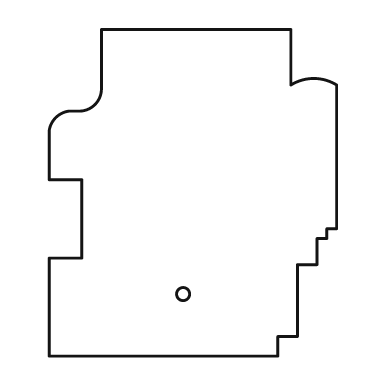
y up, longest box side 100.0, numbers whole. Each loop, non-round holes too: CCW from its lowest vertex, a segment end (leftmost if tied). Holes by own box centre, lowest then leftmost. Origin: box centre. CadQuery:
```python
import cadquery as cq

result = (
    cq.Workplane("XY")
    .moveTo(-44.0, -50.0)
    .lineTo(26.0, -50.0)
    .lineTo(26.0, -44.0)
    .lineTo(32.0, -44.0)
    .lineTo(32.0, -22.0)
    .lineTo(38.0, -22.0)
    .lineTo(38.0, -14.0)
    .lineTo(41.0, -14.0)
    .lineTo(41.0, -11.0)
    .lineTo(44.0, -11.0)
    .lineTo(44.0, 33.0)
    .threePointArc((37.0, 35.0), (30.0, 33.0))
    .lineTo(30.0, 50.0)
    .lineTo(-28.0, 50.0)
    .lineTo(-28.0, 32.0)
    .threePointArc((-30.0, 27.0), (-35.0, 25.0))
    .lineTo(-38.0, 25.0)
    .threePointArc((-42.0, 23.0), (-44.0, 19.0))
    .lineTo(-44.0, 4.0)
    .lineTo(-34.0, 4.0)
    .lineTo(-34.0, -20.0)
    .lineTo(-44.0, -20.0)
    .close()
    .moveTo(-3.0, -31.0)
    .circle(2.0)
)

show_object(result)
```